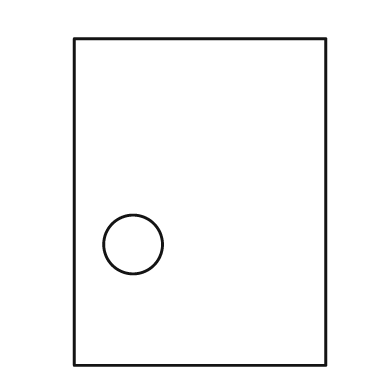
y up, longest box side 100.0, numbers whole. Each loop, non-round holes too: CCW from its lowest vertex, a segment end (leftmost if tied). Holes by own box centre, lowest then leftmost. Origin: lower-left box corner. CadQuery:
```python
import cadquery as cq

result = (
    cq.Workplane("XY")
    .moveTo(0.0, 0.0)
    .lineTo(77.0, 0.0)
    .lineTo(77.0, 100.0)
    .lineTo(0.0, 100.0)
    .close()
    .moveTo(18.0, 37.0)
    .circle(9.0)
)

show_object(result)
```